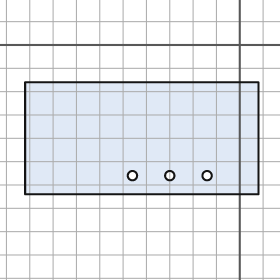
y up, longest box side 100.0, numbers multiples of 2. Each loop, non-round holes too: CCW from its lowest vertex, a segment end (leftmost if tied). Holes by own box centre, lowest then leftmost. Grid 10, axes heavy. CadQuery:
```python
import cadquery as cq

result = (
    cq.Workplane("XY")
    .moveTo(-92.0, -64.0)
    .lineTo(8.0, -64.0)
    .lineTo(8.0, -16.0)
    .lineTo(-92.0, -16.0)
    .close()
    .moveTo(-46.0, -56.0)
    .circle(2.0)
    .moveTo(-30.0, -56.0)
    .circle(2.0)
    .moveTo(-14.0, -56.0)
    .circle(2.0)
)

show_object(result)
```